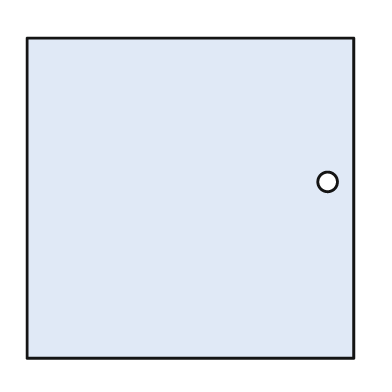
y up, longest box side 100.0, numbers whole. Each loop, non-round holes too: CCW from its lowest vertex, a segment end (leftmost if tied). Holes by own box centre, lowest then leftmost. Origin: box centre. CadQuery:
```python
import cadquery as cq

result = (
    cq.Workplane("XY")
    .moveTo(-50.0, -49.0)
    .lineTo(50.0, -49.0)
    .lineTo(50.0, 49.0)
    .lineTo(-50.0, 49.0)
    .close()
    .moveTo(42.0, 5.0)
    .circle(3.0)
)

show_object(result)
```